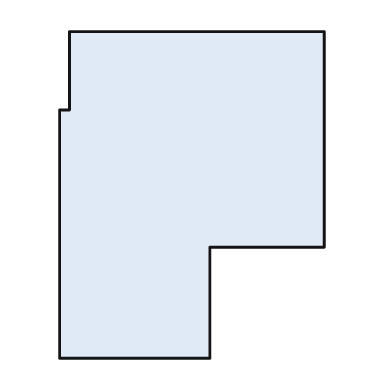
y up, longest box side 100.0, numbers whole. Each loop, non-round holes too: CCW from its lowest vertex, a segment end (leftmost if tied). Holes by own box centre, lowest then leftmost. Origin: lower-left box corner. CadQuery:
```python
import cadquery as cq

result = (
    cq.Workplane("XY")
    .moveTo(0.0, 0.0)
    .lineTo(46.0, 0.0)
    .lineTo(46.0, 34.0)
    .lineTo(81.0, 34.0)
    .lineTo(81.0, 100.0)
    .lineTo(3.0, 100.0)
    .lineTo(3.0, 76.0)
    .lineTo(0.0, 76.0)
    .close()
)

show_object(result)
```